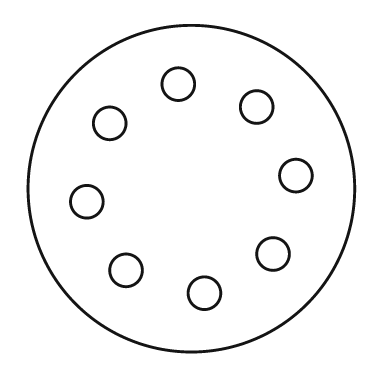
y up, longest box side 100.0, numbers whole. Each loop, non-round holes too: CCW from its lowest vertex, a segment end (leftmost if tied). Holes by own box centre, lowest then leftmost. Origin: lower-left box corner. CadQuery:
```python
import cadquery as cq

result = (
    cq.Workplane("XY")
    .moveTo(50.0, 50.0)
    .circle(50.0)
    .moveTo(54.0, 18.0)
    .circle(5.0)
    .moveTo(30.0, 25.0)
    .circle(5.0)
    .moveTo(75.0, 30.0)
    .circle(5.0)
    .moveTo(18.0, 46.0)
    .circle(5.0)
    .moveTo(82.0, 54.0)
    .circle(5.0)
    .moveTo(25.0, 70.0)
    .circle(5.0)
    .moveTo(70.0, 75.0)
    .circle(5.0)
    .moveTo(46.0, 82.0)
    .circle(5.0)
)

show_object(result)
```